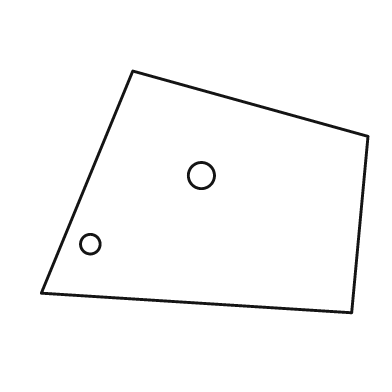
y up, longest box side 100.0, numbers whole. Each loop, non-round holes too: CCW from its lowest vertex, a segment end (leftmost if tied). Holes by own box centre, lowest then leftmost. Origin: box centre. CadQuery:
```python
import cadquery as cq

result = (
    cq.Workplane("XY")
    .moveTo(45.0, -37.0)
    .lineTo(50.0, 17.0)
    .lineTo(-22.0, 37.0)
    .lineTo(-50.0, -31.0)
    .close()
    .moveTo(-35.0, -16.0)
    .circle(3.0)
    .moveTo(-1.0, 5.0)
    .circle(4.0)
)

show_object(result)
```